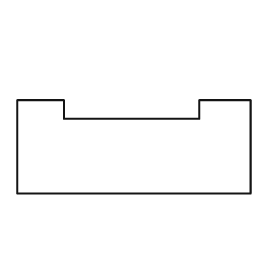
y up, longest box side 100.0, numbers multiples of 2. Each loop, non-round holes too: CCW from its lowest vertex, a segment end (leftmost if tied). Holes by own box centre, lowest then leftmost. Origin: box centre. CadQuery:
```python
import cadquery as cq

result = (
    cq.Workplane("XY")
    .moveTo(-50.0, -20.0)
    .lineTo(50.0, -20.0)
    .lineTo(50.0, 20.0)
    .lineTo(28.0, 20.0)
    .lineTo(28.0, 12.0)
    .lineTo(-30.0, 12.0)
    .lineTo(-30.0, 20.0)
    .lineTo(-50.0, 20.0)
    .close()
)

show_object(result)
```